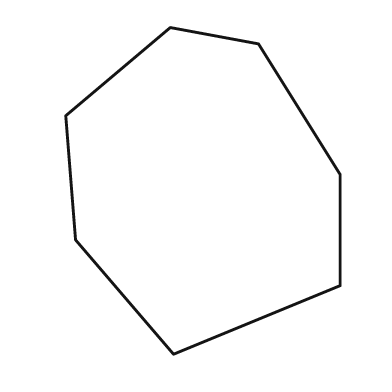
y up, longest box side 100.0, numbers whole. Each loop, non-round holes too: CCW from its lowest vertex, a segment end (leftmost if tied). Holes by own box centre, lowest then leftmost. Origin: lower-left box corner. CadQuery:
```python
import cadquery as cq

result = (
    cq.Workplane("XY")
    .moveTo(33.0, 0.0)
    .lineTo(84.0, 21.0)
    .lineTo(84.0, 55.0)
    .lineTo(59.0, 95.0)
    .lineTo(32.0, 100.0)
    .lineTo(0.0, 73.0)
    .lineTo(3.0, 35.0)
    .close()
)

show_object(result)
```